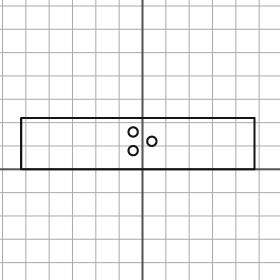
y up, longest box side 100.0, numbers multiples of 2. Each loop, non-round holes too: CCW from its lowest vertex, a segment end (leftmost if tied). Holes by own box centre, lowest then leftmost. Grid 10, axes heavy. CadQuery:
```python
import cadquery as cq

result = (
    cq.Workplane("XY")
    .moveTo(-52.0, 0.0)
    .lineTo(48.0, 0.0)
    .lineTo(48.0, 22.0)
    .lineTo(-52.0, 22.0)
    .close()
    .moveTo(-4.0, 8.0)
    .circle(2.0)
    .moveTo(4.0, 12.0)
    .circle(2.0)
    .moveTo(-4.0, 16.0)
    .circle(2.0)
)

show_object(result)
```